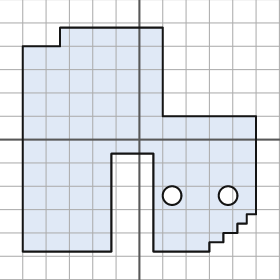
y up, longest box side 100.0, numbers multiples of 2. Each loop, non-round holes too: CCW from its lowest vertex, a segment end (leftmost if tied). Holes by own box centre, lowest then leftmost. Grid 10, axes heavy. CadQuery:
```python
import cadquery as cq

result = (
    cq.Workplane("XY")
    .moveTo(-50.0, -48.0)
    .lineTo(-12.0, -48.0)
    .lineTo(-12.0, -6.0)
    .lineTo(6.0, -6.0)
    .lineTo(6.0, -48.0)
    .lineTo(30.0, -48.0)
    .lineTo(30.0, -44.0)
    .lineTo(36.0, -44.0)
    .lineTo(36.0, -40.0)
    .lineTo(42.0, -40.0)
    .lineTo(42.0, -36.0)
    .lineTo(46.0, -36.0)
    .lineTo(46.0, -32.0)
    .lineTo(50.0, -32.0)
    .lineTo(50.0, 10.0)
    .lineTo(10.0, 10.0)
    .lineTo(10.0, 48.0)
    .lineTo(-34.0, 48.0)
    .lineTo(-34.0, 40.0)
    .lineTo(-50.0, 40.0)
    .close()
    .moveTo(14.0, -24.0)
    .circle(4.0)
    .moveTo(38.0, -24.0)
    .circle(4.0)
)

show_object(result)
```